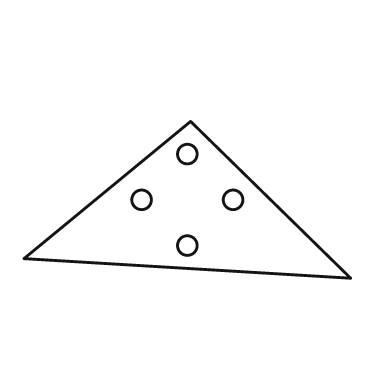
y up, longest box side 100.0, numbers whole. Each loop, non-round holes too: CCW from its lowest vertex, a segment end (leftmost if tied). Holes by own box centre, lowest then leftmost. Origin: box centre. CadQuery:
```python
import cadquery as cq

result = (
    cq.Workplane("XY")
    .moveTo(50.0, -24.0)
    .lineTo(1.0, 24.0)
    .lineTo(-50.0, -18.0)
    .close()
    .moveTo(0.0, -14.0)
    .circle(3.0)
    .moveTo(-14.0, 0.0)
    .circle(3.0)
    .moveTo(14.0, 0.0)
    .circle(3.0)
    .moveTo(0.0, 14.0)
    .circle(3.0)
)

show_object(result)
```